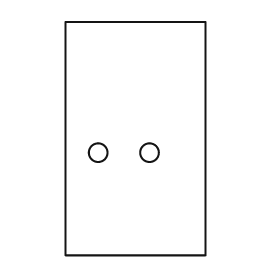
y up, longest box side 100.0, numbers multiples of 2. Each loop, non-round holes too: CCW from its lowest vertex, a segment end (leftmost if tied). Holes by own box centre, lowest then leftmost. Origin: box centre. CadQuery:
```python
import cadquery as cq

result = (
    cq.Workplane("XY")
    .moveTo(-30.0, -50.0)
    .lineTo(30.0, -50.0)
    .lineTo(30.0, 50.0)
    .lineTo(-30.0, 50.0)
    .close()
    .moveTo(-16.0, -6.0)
    .circle(4.0)
    .moveTo(6.0, -6.0)
    .circle(4.0)
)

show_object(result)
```